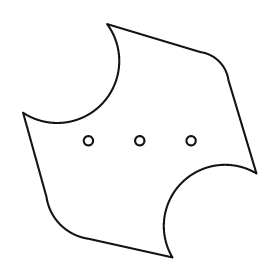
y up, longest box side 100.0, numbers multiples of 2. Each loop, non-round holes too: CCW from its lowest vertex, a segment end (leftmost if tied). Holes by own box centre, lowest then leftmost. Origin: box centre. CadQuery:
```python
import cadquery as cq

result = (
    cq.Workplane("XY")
    .moveTo(14.0, -50.0)
    .threePointArc((18.0, -18.0), (50.0, -14.0))
    .lineTo(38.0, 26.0)
    .threePointArc((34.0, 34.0), (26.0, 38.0))
    .lineTo(-14.0, 50.0)
    .threePointArc((-16.0, 16.0), (-50.0, 12.0))
    .lineTo(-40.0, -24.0)
    .threePointArc((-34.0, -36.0), (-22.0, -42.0))
    .close()
    .moveTo(-22.0, 0.0)
    .circle(2.0)
    .moveTo(0.0, 0.0)
    .circle(2.0)
    .moveTo(22.0, 0.0)
    .circle(2.0)
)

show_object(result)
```